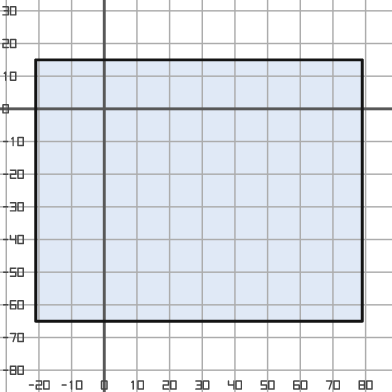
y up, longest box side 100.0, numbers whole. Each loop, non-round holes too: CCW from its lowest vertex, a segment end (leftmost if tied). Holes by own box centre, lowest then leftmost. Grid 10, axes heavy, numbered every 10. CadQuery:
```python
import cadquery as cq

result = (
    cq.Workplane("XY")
    .moveTo(-21.0, -65.0)
    .lineTo(79.0, -65.0)
    .lineTo(79.0, 15.0)
    .lineTo(-21.0, 15.0)
    .close()
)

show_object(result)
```